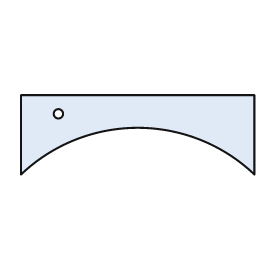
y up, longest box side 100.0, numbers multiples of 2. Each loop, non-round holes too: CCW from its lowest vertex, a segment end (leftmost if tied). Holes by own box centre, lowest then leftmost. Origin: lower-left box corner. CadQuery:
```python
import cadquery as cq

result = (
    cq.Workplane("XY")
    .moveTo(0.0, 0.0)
    .threePointArc((50.0, 20.0), (100.0, 0.0))
    .lineTo(100.0, 34.0)
    .lineTo(0.0, 34.0)
    .close()
    .moveTo(16.0, 26.0)
    .circle(2.0)
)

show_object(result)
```